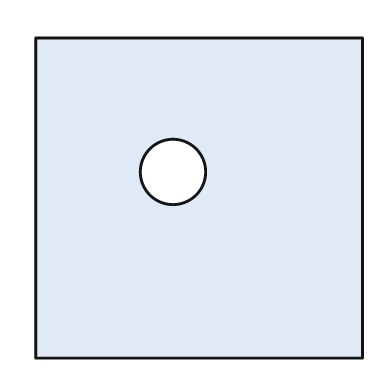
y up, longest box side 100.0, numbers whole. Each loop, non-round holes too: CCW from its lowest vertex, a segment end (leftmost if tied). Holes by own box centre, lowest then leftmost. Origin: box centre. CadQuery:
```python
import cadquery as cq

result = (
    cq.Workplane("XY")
    .moveTo(-50.0, -49.0)
    .lineTo(50.0, -49.0)
    .lineTo(50.0, 49.0)
    .lineTo(-50.0, 49.0)
    .close()
    .moveTo(-8.0, 8.0)
    .circle(10.0)
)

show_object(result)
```